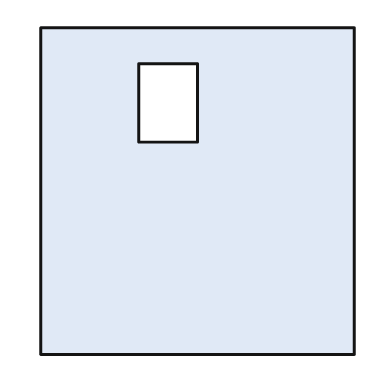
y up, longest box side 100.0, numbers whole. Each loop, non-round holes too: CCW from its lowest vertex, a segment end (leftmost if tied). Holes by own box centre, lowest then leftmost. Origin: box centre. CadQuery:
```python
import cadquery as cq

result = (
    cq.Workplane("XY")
    .moveTo(-48.0, -50.0)
    .lineTo(48.0, -50.0)
    .lineTo(48.0, 50.0)
    .lineTo(-48.0, 50.0)
    .close()
    .moveTo(-18.0, 15.0)
    .lineTo(0.0, 15.0)
    .lineTo(0.0, 39.0)
    .lineTo(-18.0, 39.0)
    .close()
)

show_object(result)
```